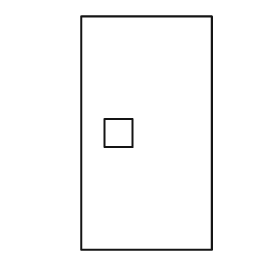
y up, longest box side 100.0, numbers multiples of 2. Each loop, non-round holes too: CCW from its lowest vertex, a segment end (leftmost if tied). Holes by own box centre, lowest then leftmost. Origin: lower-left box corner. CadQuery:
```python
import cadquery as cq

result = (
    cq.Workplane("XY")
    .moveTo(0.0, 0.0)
    .lineTo(56.0, 0.0)
    .lineTo(56.0, 100.0)
    .lineTo(0.0, 100.0)
    .close()
    .moveTo(10.0, 44.0)
    .lineTo(22.0, 44.0)
    .lineTo(22.0, 56.0)
    .lineTo(10.0, 56.0)
    .close()
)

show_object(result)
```